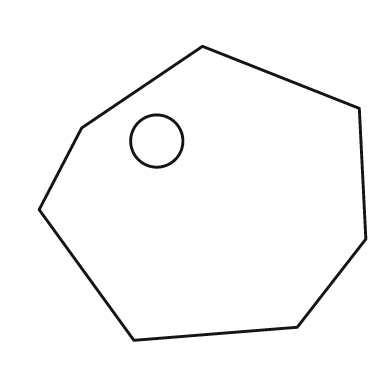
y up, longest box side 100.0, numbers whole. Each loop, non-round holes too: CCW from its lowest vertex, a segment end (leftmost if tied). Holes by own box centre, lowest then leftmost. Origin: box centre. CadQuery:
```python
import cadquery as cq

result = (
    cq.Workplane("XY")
    .moveTo(-21.0, -45.0)
    .lineTo(29.0, -41.0)
    .lineTo(50.0, -14.0)
    .lineTo(48.0, 26.0)
    .lineTo(0.0, 45.0)
    .lineTo(-37.0, 20.0)
    .lineTo(-50.0, -5.0)
    .close()
    .moveTo(-14.0, 16.0)
    .circle(8.0)
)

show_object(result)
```